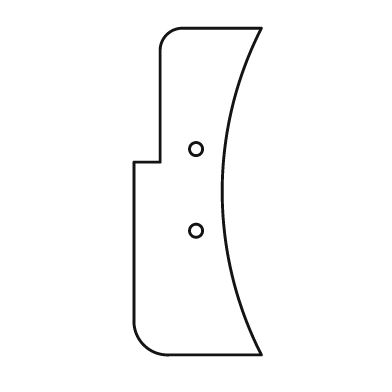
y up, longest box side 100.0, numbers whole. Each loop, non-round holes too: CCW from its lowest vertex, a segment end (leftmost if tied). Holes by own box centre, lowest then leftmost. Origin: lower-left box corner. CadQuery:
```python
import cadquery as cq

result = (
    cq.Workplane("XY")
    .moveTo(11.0, 0.0)
    .lineTo(39.0, 0.0)
    .threePointArc((27.0, 50.0), (39.0, 100.0))
    .lineTo(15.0, 100.0)
    .threePointArc((10.0, 98.0), (8.0, 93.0))
    .lineTo(8.0, 59.0)
    .lineTo(0.0, 59.0)
    .lineTo(0.0, 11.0)
    .threePointArc((3.0, 3.0), (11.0, 0.0))
    .close()
    .moveTo(19.0, 38.0)
    .circle(2.0)
    .moveTo(19.0, 63.0)
    .circle(2.0)
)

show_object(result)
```